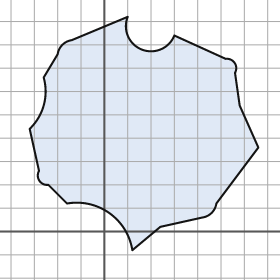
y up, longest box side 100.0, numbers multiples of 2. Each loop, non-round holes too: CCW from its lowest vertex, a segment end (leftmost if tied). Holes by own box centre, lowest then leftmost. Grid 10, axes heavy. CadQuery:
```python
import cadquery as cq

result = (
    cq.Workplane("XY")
    .moveTo(12.0, -8.0)
    .lineTo(24.0, 2.0)
    .lineTo(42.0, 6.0)
    .threePointArc((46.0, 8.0), (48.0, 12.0))
    .lineTo(66.0, 36.0)
    .lineTo(58.0, 54.0)
    .lineTo(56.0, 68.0)
    .threePointArc((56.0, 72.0), (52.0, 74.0))
    .lineTo(30.0, 84.0)
    .threePointArc((16.0, 78.0), (10.0, 92.0))
    .lineTo(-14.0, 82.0)
    .threePointArc((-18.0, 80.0), (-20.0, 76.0))
    .lineTo(-26.0, 66.0)
    .threePointArc((-26.0, 54.0), (-32.0, 44.0))
    .lineTo(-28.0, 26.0)
    .threePointArc((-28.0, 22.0), (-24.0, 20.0))
    .lineTo(-16.0, 12.0)
    .threePointArc((2.0, 8.0), (12.0, -8.0))
    .close()
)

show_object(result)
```